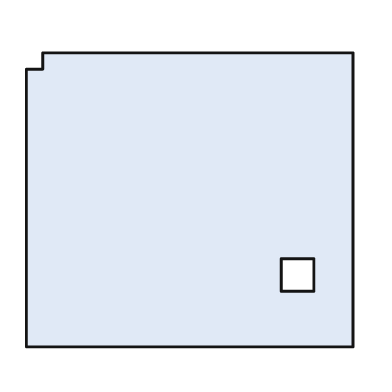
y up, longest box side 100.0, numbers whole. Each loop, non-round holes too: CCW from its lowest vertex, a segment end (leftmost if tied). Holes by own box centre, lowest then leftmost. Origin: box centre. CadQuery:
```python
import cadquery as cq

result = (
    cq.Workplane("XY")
    .moveTo(-50.0, -45.0)
    .lineTo(50.0, -45.0)
    .lineTo(50.0, 45.0)
    .lineTo(-45.0, 45.0)
    .lineTo(-45.0, 40.0)
    .lineTo(-50.0, 40.0)
    .close()
    .moveTo(28.0, -28.0)
    .lineTo(38.0, -28.0)
    .lineTo(38.0, -18.0)
    .lineTo(28.0, -18.0)
    .close()
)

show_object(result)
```